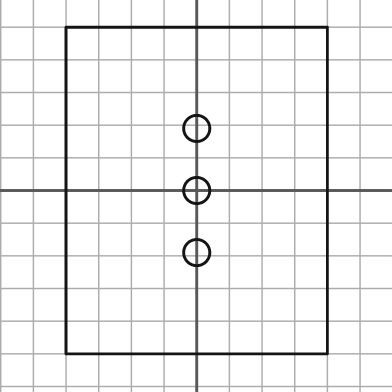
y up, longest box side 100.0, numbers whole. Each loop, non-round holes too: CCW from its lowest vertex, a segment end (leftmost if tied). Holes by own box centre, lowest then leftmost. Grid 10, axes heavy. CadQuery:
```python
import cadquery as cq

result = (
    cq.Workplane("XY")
    .moveTo(-40.0, -50.0)
    .lineTo(40.0, -50.0)
    .lineTo(40.0, 50.0)
    .lineTo(-40.0, 50.0)
    .close()
    .moveTo(0.0, -19.0)
    .circle(4.0)
    .moveTo(0.0, 0.0)
    .circle(4.0)
    .moveTo(0.0, 19.0)
    .circle(4.0)
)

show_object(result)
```